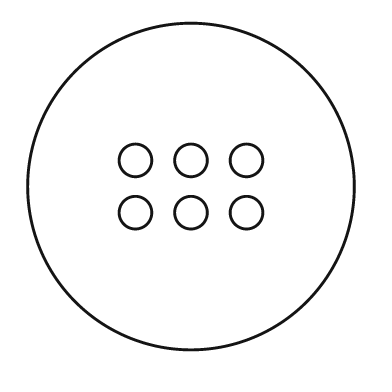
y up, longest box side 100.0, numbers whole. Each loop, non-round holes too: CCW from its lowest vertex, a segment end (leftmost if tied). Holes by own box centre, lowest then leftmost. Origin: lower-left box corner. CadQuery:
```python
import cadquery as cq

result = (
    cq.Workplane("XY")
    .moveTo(50.0, 50.0)
    .circle(50.0)
    .moveTo(33.0, 42.0)
    .circle(5.0)
    .moveTo(50.0, 42.0)
    .circle(5.0)
    .moveTo(67.0, 42.0)
    .circle(5.0)
    .moveTo(33.0, 58.0)
    .circle(5.0)
    .moveTo(50.0, 58.0)
    .circle(5.0)
    .moveTo(67.0, 58.0)
    .circle(5.0)
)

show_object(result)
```